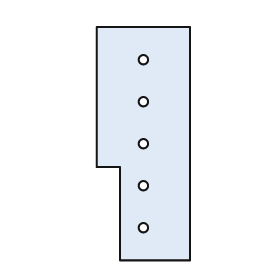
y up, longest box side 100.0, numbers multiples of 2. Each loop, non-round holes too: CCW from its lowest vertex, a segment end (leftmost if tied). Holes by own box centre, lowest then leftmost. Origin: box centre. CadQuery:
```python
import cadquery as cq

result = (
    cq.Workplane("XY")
    .moveTo(-10.0, -50.0)
    .lineTo(20.0, -50.0)
    .lineTo(20.0, 50.0)
    .lineTo(-20.0, 50.0)
    .lineTo(-20.0, -10.0)
    .lineTo(-10.0, -10.0)
    .close()
    .moveTo(0.0, -36.0)
    .circle(2.0)
    .moveTo(0.0, -18.0)
    .circle(2.0)
    .moveTo(0.0, 0.0)
    .circle(2.0)
    .moveTo(0.0, 18.0)
    .circle(2.0)
    .moveTo(0.0, 36.0)
    .circle(2.0)
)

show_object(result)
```